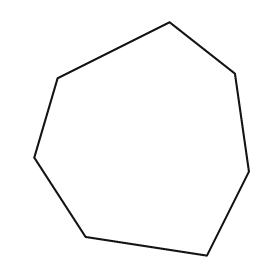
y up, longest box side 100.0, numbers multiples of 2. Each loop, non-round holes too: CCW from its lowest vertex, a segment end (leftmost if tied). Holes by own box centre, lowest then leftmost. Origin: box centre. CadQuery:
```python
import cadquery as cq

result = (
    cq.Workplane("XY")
    .moveTo(28.0, -50.0)
    .lineTo(46.0, -14.0)
    .lineTo(40.0, 28.0)
    .lineTo(12.0, 50.0)
    .lineTo(-36.0, 26.0)
    .lineTo(-46.0, -8.0)
    .lineTo(-24.0, -42.0)
    .close()
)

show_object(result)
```